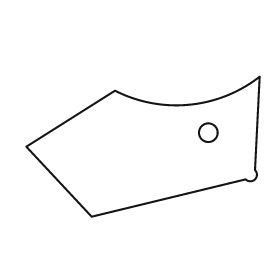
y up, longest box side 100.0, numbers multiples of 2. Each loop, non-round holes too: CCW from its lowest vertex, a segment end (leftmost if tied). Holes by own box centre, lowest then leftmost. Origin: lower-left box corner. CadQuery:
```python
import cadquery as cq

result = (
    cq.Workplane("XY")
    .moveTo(28.0, 0.0)
    .lineTo(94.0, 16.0)
    .threePointArc((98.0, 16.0), (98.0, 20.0))
    .lineTo(100.0, 60.0)
    .threePointArc((70.0, 48.0), (38.0, 54.0))
    .lineTo(0.0, 30.0)
    .close()
    .moveTo(78.0, 36.0)
    .circle(4.0)
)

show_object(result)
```